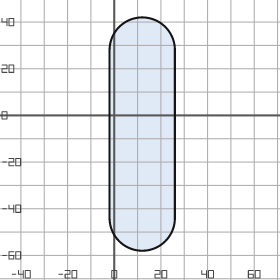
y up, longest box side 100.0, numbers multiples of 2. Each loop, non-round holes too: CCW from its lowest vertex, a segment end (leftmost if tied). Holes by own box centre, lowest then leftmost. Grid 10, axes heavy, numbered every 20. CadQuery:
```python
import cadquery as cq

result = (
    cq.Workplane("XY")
    .moveTo(-2.0, -44.0)
    .threePointArc((12.0, -58.0), (26.0, -44.0))
    .lineTo(26.0, 28.0)
    .threePointArc((12.0, 42.0), (-2.0, 28.0))
    .close()
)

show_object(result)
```